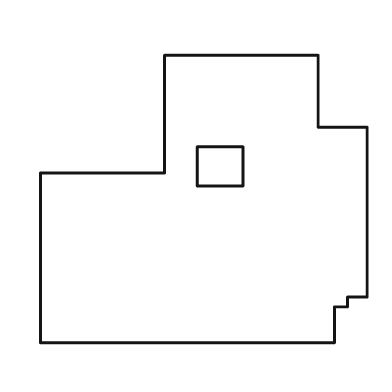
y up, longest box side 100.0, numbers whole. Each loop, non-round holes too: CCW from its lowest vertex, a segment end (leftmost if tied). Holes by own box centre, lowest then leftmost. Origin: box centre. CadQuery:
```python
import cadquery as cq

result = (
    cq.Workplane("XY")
    .moveTo(-50.0, -44.0)
    .lineTo(40.0, -44.0)
    .lineTo(40.0, -33.0)
    .lineTo(44.0, -33.0)
    .lineTo(44.0, -30.0)
    .lineTo(50.0, -30.0)
    .lineTo(50.0, 22.0)
    .lineTo(35.0, 22.0)
    .lineTo(35.0, 44.0)
    .lineTo(-12.0, 44.0)
    .lineTo(-12.0, 8.0)
    .lineTo(-50.0, 8.0)
    .close()
    .moveTo(-2.0, 4.0)
    .lineTo(12.0, 4.0)
    .lineTo(12.0, 16.0)
    .lineTo(-2.0, 16.0)
    .close()
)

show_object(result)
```